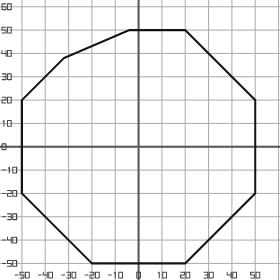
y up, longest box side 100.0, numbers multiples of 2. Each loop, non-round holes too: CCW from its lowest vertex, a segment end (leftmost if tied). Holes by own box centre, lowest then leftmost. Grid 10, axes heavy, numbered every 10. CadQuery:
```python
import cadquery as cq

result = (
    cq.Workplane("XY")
    .moveTo(-20.0, -50.0)
    .lineTo(20.0, -50.0)
    .lineTo(50.0, -20.0)
    .lineTo(50.0, 20.0)
    .lineTo(20.0, 50.0)
    .lineTo(-4.0, 50.0)
    .lineTo(-32.0, 38.0)
    .lineTo(-50.0, 20.0)
    .lineTo(-50.0, -20.0)
    .close()
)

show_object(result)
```